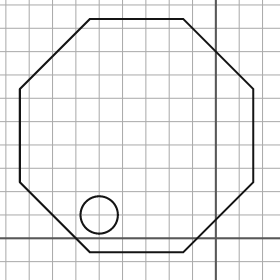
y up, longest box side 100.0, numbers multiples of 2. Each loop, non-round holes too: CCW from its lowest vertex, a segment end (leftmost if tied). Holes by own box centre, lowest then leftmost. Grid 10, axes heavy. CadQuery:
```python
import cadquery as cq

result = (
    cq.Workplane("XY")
    .moveTo(-54.0, -6.0)
    .lineTo(-14.0, -6.0)
    .lineTo(16.0, 24.0)
    .lineTo(16.0, 64.0)
    .lineTo(-14.0, 94.0)
    .lineTo(-54.0, 94.0)
    .lineTo(-84.0, 64.0)
    .lineTo(-84.0, 24.0)
    .close()
    .moveTo(-50.0, 10.0)
    .circle(8.0)
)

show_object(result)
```